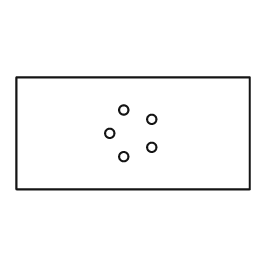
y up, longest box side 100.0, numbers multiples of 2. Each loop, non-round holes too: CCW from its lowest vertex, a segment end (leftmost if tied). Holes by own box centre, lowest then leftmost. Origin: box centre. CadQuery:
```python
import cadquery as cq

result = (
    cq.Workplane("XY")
    .moveTo(-50.0, -24.0)
    .lineTo(50.0, -24.0)
    .lineTo(50.0, 24.0)
    .lineTo(-50.0, 24.0)
    .close()
    .moveTo(-4.0, -10.0)
    .circle(2.0)
    .moveTo(8.0, -6.0)
    .circle(2.0)
    .moveTo(-10.0, 0.0)
    .circle(2.0)
    .moveTo(8.0, 6.0)
    .circle(2.0)
    .moveTo(-4.0, 10.0)
    .circle(2.0)
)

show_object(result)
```